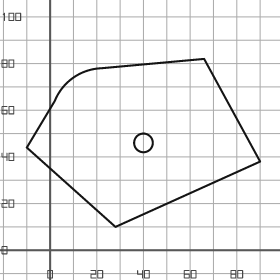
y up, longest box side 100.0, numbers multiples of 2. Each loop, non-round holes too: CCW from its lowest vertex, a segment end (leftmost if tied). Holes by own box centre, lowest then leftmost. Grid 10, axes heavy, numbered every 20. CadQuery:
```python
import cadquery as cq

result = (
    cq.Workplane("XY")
    .moveTo(28.0, 10.0)
    .lineTo(90.0, 38.0)
    .lineTo(66.0, 82.0)
    .lineTo(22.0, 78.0)
    .threePointArc((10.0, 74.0), (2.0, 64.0))
    .lineTo(-10.0, 44.0)
    .close()
    .moveTo(40.0, 46.0)
    .circle(4.0)
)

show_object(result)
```